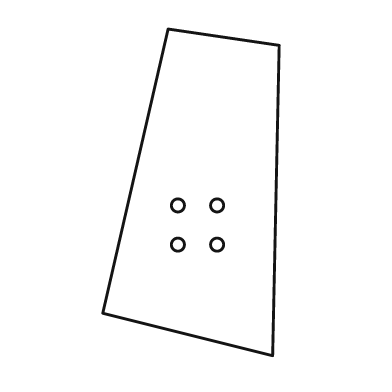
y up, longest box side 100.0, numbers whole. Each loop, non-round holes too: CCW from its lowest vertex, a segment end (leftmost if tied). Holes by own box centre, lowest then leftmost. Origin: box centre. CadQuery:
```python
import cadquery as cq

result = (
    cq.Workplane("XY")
    .moveTo(25.0, -50.0)
    .lineTo(27.0, 45.0)
    .lineTo(-7.0, 50.0)
    .lineTo(-27.0, -37.0)
    .close()
    .moveTo(-4.0, -16.0)
    .circle(2.0)
    .moveTo(8.0, -16.0)
    .circle(2.0)
    .moveTo(-4.0, -4.0)
    .circle(2.0)
    .moveTo(8.0, -4.0)
    .circle(2.0)
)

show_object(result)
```